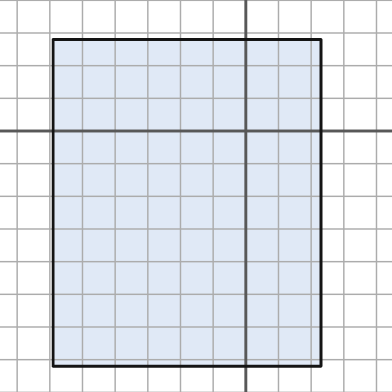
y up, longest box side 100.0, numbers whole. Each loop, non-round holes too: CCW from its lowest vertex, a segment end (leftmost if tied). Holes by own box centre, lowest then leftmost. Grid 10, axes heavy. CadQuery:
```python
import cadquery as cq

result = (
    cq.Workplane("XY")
    .moveTo(-59.0, -72.0)
    .lineTo(23.0, -72.0)
    .lineTo(23.0, 28.0)
    .lineTo(-59.0, 28.0)
    .close()
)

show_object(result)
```